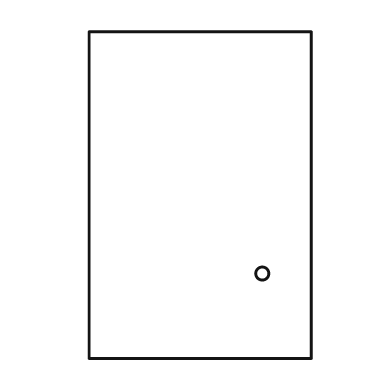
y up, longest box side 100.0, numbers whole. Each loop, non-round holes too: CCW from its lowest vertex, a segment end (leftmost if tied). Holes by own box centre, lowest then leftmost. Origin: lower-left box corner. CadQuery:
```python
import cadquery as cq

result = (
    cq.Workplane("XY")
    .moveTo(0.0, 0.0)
    .lineTo(68.0, 0.0)
    .lineTo(68.0, 100.0)
    .lineTo(0.0, 100.0)
    .close()
    .moveTo(53.0, 26.0)
    .circle(2.0)
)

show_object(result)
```